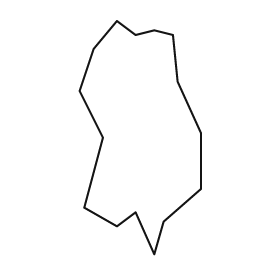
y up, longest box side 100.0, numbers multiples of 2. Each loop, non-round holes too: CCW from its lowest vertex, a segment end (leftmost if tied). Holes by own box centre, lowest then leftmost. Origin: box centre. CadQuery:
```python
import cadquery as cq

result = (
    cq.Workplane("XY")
    .moveTo(6.0, -50.0)
    .lineTo(10.0, -36.0)
    .lineTo(26.0, -22.0)
    .lineTo(26.0, 2.0)
    .lineTo(16.0, 24.0)
    .lineTo(14.0, 44.0)
    .lineTo(6.0, 46.0)
    .lineTo(-2.0, 44.0)
    .lineTo(-10.0, 50.0)
    .lineTo(-20.0, 38.0)
    .lineTo(-26.0, 20.0)
    .lineTo(-16.0, 0.0)
    .lineTo(-24.0, -30.0)
    .lineTo(-10.0, -38.0)
    .lineTo(-2.0, -32.0)
    .close()
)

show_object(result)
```